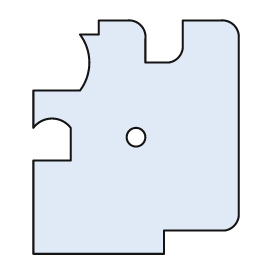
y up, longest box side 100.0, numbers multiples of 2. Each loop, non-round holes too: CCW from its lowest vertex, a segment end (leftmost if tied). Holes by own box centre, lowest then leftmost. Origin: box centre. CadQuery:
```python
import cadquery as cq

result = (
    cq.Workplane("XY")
    .moveTo(-44.0, -50.0)
    .lineTo(12.0, -50.0)
    .lineTo(12.0, -40.0)
    .lineTo(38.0, -40.0)
    .threePointArc((42.0, -38.0), (44.0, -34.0))
    .lineTo(44.0, 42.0)
    .threePointArc((42.0, 48.0), (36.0, 50.0))
    .lineTo(20.0, 50.0)
    .lineTo(20.0, 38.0)
    .threePointArc((18.0, 34.0), (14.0, 32.0))
    .lineTo(4.0, 32.0)
    .lineTo(4.0, 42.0)
    .threePointArc((2.0, 48.0), (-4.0, 50.0))
    .lineTo(-16.0, 50.0)
    .lineTo(-16.0, 44.0)
    .lineTo(-24.0, 44.0)
    .threePointArc((-20.0, 32.0), (-24.0, 20.0))
    .lineTo(-44.0, 20.0)
    .lineTo(-44.0, 4.0)
    .threePointArc((-36.0, 8.0), (-28.0, 4.0))
    .lineTo(-28.0, -10.0)
    .lineTo(-44.0, -10.0)
    .close()
    .moveTo(0.0, 0.0)
    .circle(4.0)
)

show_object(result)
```